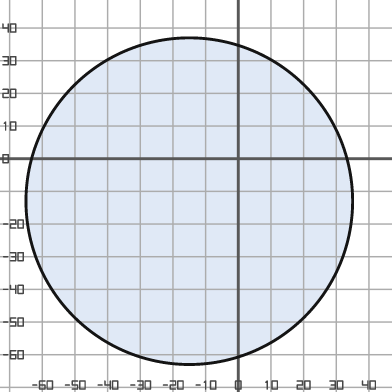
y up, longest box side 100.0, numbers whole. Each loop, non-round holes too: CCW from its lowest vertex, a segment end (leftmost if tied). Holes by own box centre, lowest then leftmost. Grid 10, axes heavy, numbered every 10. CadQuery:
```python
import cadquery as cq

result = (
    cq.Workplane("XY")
    .moveTo(-15.0, -13.0)
    .circle(50.0)
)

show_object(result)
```